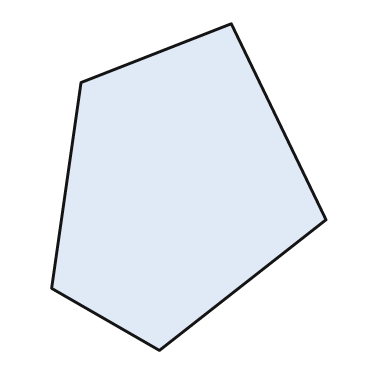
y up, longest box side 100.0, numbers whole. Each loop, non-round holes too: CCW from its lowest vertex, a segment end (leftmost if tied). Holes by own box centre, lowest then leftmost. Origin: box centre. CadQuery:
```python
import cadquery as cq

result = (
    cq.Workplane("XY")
    .moveTo(-9.0, -50.0)
    .lineTo(42.0, -10.0)
    .lineTo(13.0, 50.0)
    .lineTo(-33.0, 32.0)
    .lineTo(-42.0, -31.0)
    .close()
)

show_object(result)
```